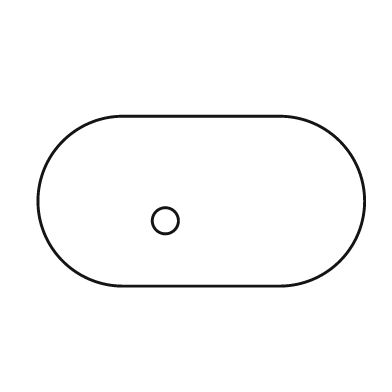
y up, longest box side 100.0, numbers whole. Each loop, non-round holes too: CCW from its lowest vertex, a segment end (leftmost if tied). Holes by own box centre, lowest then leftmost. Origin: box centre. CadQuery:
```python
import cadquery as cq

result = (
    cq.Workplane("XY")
    .moveTo(-24.0, -26.0)
    .lineTo(24.0, -26.0)
    .threePointArc((50.0, 0.0), (24.0, 26.0))
    .lineTo(-24.0, 26.0)
    .threePointArc((-50.0, 0.0), (-24.0, -26.0))
    .close()
    .moveTo(-11.0, -6.0)
    .circle(4.0)
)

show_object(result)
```